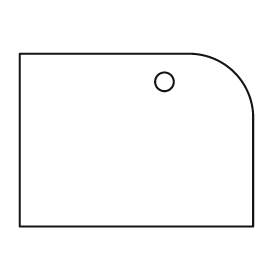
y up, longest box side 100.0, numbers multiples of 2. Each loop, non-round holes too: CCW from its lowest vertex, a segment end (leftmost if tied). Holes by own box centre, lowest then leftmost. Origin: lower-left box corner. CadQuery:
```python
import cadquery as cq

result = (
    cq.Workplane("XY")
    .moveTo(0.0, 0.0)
    .lineTo(100.0, 0.0)
    .lineTo(100.0, 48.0)
    .threePointArc((92.0, 66.0), (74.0, 74.0))
    .lineTo(0.0, 74.0)
    .close()
    .moveTo(62.0, 62.0)
    .circle(4.0)
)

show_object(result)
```